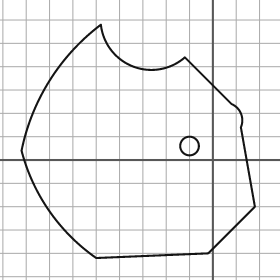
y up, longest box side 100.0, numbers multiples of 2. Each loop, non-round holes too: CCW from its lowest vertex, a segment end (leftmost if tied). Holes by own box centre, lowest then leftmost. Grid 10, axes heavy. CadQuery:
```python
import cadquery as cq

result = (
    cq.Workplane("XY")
    .moveTo(-50.0, -42.0)
    .lineTo(-2.0, -40.0)
    .lineTo(18.0, -20.0)
    .lineTo(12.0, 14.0)
    .threePointArc((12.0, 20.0), (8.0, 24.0))
    .lineTo(-12.0, 44.0)
    .threePointArc((-34.0, 40.0), (-48.0, 58.0))
    .threePointArc((-70.0, 34.0), (-82.0, 4.0))
    .threePointArc((-70.0, -22.0), (-50.0, -42.0))
    .close()
    .moveTo(-10.0, 6.0)
    .circle(4.0)
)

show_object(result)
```